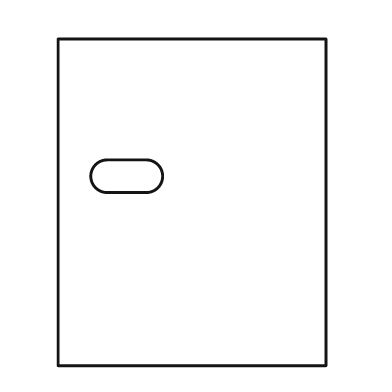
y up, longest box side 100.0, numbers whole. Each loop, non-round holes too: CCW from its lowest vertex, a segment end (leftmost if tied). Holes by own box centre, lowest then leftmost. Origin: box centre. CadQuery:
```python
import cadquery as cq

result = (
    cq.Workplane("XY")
    .moveTo(-41.0, -50.0)
    .lineTo(41.0, -50.0)
    .lineTo(41.0, 50.0)
    .lineTo(-41.0, 50.0)
    .close()
    .moveTo(-26.0, 3.0)
    .lineTo(-14.0, 3.0)
    .threePointArc((-9.0, 8.0), (-14.0, 13.0))
    .lineTo(-26.0, 13.0)
    .threePointArc((-31.0, 8.0), (-26.0, 3.0))
    .close()
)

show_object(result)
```